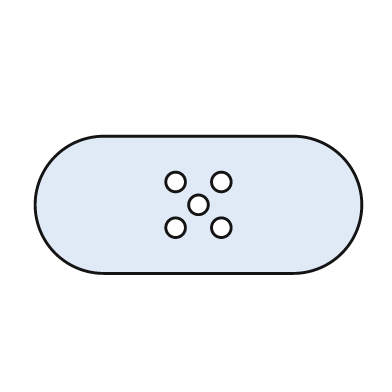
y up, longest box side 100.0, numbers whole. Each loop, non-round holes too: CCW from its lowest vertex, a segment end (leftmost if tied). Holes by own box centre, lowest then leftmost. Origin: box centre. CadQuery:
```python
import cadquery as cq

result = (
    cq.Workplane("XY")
    .moveTo(-29.0, -21.0)
    .lineTo(29.0, -21.0)
    .threePointArc((50.0, 0.0), (29.0, 21.0))
    .lineTo(-29.0, 21.0)
    .threePointArc((-50.0, 0.0), (-29.0, -21.0))
    .close()
    .moveTo(-7.0, -7.0)
    .circle(3.0)
    .moveTo(7.0, -7.0)
    .circle(3.0)
    .moveTo(0.0, 0.0)
    .circle(3.0)
    .moveTo(-7.0, 7.0)
    .circle(3.0)
    .moveTo(7.0, 7.0)
    .circle(3.0)
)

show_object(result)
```